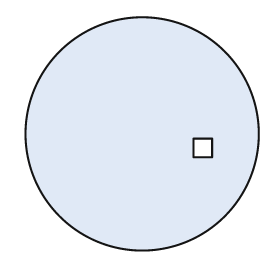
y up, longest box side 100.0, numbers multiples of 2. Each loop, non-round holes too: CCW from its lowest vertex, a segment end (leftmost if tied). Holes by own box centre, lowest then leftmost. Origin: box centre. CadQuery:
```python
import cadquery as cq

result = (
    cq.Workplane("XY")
    .moveTo(0.0, 0.0)
    .circle(50.0)
    .moveTo(22.0, -10.0)
    .lineTo(30.0, -10.0)
    .lineTo(30.0, -2.0)
    .lineTo(22.0, -2.0)
    .close()
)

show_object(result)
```